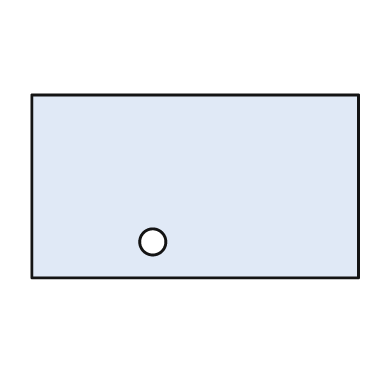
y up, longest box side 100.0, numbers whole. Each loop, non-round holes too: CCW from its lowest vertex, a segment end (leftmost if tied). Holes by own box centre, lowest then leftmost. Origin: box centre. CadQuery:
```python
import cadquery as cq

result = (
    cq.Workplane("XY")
    .moveTo(-50.0, -28.0)
    .lineTo(50.0, -28.0)
    .lineTo(50.0, 28.0)
    .lineTo(-50.0, 28.0)
    .close()
    .moveTo(-13.0, -17.0)
    .circle(4.0)
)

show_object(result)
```